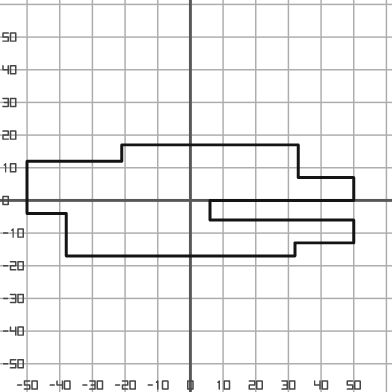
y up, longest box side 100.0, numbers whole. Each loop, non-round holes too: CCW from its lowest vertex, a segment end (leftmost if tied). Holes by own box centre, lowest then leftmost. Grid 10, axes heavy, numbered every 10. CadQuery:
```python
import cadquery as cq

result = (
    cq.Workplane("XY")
    .moveTo(-38.0, -17.0)
    .lineTo(32.0, -17.0)
    .lineTo(32.0, -13.0)
    .lineTo(50.0, -13.0)
    .lineTo(50.0, -6.0)
    .lineTo(6.0, -6.0)
    .lineTo(6.0, 0.0)
    .lineTo(50.0, 0.0)
    .lineTo(50.0, 7.0)
    .lineTo(33.0, 7.0)
    .lineTo(33.0, 17.0)
    .lineTo(-21.0, 17.0)
    .lineTo(-21.0, 12.0)
    .lineTo(-50.0, 12.0)
    .lineTo(-50.0, -4.0)
    .lineTo(-38.0, -4.0)
    .close()
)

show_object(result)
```